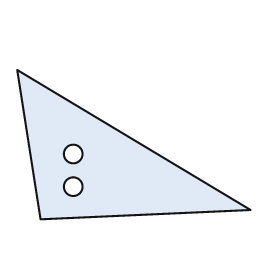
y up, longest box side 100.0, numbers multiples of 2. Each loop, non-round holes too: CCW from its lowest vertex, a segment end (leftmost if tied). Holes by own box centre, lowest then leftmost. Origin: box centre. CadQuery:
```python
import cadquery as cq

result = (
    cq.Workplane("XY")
    .moveTo(-40.0, -32.0)
    .lineTo(50.0, -28.0)
    .lineTo(-50.0, 32.0)
    .close()
    .moveTo(-26.0, -18.0)
    .circle(4.0)
    .moveTo(-26.0, -4.0)
    .circle(4.0)
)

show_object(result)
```